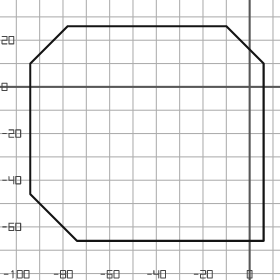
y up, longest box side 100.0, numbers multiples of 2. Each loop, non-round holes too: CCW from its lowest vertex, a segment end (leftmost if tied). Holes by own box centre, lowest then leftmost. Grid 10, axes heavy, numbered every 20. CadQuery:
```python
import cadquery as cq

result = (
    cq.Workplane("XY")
    .moveTo(-74.0, -66.0)
    .lineTo(6.0, -66.0)
    .lineTo(6.0, 10.0)
    .lineTo(-10.0, 26.0)
    .lineTo(-78.0, 26.0)
    .lineTo(-94.0, 10.0)
    .lineTo(-94.0, -46.0)
    .close()
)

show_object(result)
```